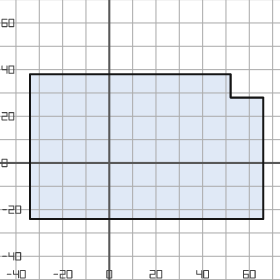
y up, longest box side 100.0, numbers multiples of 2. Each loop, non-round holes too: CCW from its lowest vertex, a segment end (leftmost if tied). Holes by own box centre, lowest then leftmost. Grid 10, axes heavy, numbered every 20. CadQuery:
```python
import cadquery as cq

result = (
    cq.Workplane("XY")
    .moveTo(-34.0, -24.0)
    .lineTo(66.0, -24.0)
    .lineTo(66.0, 28.0)
    .lineTo(52.0, 28.0)
    .lineTo(52.0, 38.0)
    .lineTo(-34.0, 38.0)
    .close()
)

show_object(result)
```